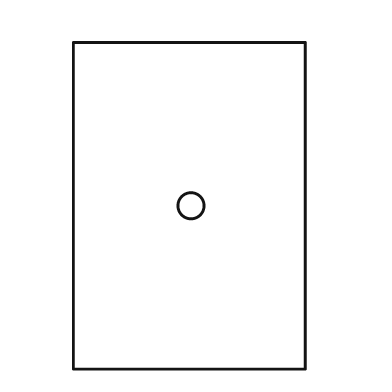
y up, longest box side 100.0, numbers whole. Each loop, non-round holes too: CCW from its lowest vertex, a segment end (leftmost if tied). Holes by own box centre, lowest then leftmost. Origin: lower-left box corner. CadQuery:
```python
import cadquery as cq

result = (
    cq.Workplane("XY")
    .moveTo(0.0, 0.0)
    .lineTo(71.0, 0.0)
    .lineTo(71.0, 100.0)
    .lineTo(0.0, 100.0)
    .close()
    .moveTo(36.0, 50.0)
    .circle(4.0)
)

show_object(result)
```